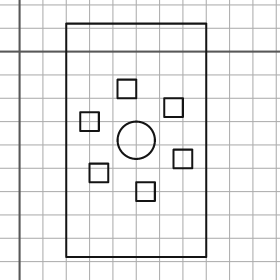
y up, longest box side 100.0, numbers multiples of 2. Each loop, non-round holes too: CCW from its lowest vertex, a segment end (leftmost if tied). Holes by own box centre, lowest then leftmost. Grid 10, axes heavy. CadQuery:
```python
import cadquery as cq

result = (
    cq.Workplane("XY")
    .moveTo(20.0, -88.0)
    .lineTo(80.0, -88.0)
    .lineTo(80.0, 12.0)
    .lineTo(20.0, 12.0)
    .close()
    .moveTo(50.0, -64.0)
    .lineTo(58.0, -64.0)
    .lineTo(58.0, -56.0)
    .lineTo(50.0, -56.0)
    .close()
    .moveTo(30.0, -56.0)
    .lineTo(38.0, -56.0)
    .lineTo(38.0, -48.0)
    .lineTo(30.0, -48.0)
    .close()
    .moveTo(66.0, -50.0)
    .lineTo(74.0, -50.0)
    .lineTo(74.0, -42.0)
    .lineTo(66.0, -42.0)
    .close()
    .moveTo(50.0, -38.0)
    .circle(8.0)
    .moveTo(26.0, -34.0)
    .lineTo(34.0, -34.0)
    .lineTo(34.0, -26.0)
    .lineTo(26.0, -26.0)
    .close()
    .moveTo(62.0, -28.0)
    .lineTo(70.0, -28.0)
    .lineTo(70.0, -20.0)
    .lineTo(62.0, -20.0)
    .close()
    .moveTo(42.0, -20.0)
    .lineTo(50.0, -20.0)
    .lineTo(50.0, -12.0)
    .lineTo(42.0, -12.0)
    .close()
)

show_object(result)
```